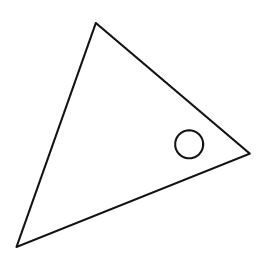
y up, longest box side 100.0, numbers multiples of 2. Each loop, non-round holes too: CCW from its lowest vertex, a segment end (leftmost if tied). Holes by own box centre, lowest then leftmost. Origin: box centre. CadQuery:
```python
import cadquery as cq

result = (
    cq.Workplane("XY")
    .moveTo(-50.0, -48.0)
    .lineTo(50.0, -8.0)
    .lineTo(-16.0, 48.0)
    .close()
    .moveTo(24.0, -4.0)
    .circle(6.0)
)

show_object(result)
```